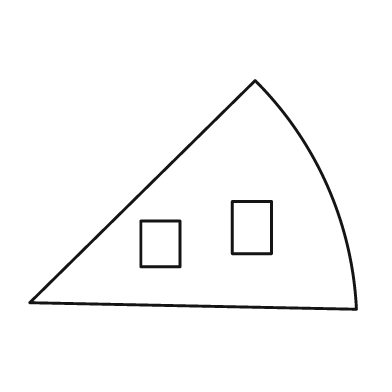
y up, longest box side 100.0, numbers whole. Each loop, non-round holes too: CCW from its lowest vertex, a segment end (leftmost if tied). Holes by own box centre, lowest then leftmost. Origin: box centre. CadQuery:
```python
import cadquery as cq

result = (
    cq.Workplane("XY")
    .moveTo(50.0, -35.0)
    .threePointArc((41.0, 3.0), (19.0, 35.0))
    .lineTo(-50.0, -33.0)
    .close()
    .moveTo(-16.0, -22.0)
    .lineTo(-4.0, -22.0)
    .lineTo(-4.0, -8.0)
    .lineTo(-16.0, -8.0)
    .close()
    .moveTo(12.0, -18.0)
    .lineTo(24.0, -18.0)
    .lineTo(24.0, -2.0)
    .lineTo(12.0, -2.0)
    .close()
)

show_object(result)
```